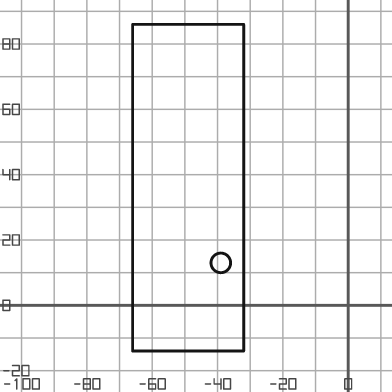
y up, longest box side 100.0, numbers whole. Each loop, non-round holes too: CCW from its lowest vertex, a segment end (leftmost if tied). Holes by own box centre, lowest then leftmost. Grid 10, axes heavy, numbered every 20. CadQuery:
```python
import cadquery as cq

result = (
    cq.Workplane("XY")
    .moveTo(-66.0, -14.0)
    .lineTo(-32.0, -14.0)
    .lineTo(-32.0, 86.0)
    .lineTo(-66.0, 86.0)
    .close()
    .moveTo(-39.0, 13.0)
    .circle(3.0)
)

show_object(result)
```